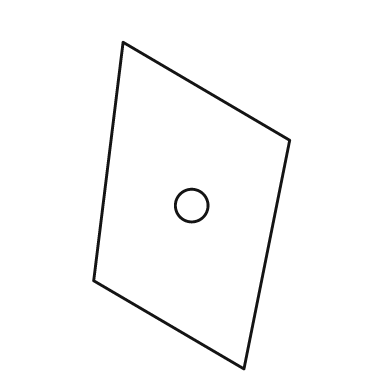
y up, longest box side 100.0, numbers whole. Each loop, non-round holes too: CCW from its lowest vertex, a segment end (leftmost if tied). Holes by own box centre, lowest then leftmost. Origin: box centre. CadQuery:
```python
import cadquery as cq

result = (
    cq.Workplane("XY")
    .moveTo(16.0, -50.0)
    .lineTo(30.0, 20.0)
    .lineTo(-21.0, 50.0)
    .lineTo(-30.0, -23.0)
    .close()
    .moveTo(0.0, 0.0)
    .circle(5.0)
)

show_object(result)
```